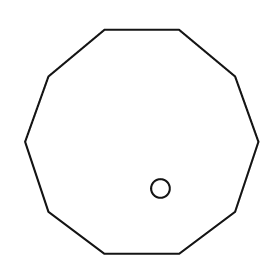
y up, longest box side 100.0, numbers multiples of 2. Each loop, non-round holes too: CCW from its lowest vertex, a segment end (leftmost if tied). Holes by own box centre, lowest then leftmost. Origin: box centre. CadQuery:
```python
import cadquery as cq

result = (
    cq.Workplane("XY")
    .moveTo(-16.0, -48.0)
    .lineTo(16.0, -48.0)
    .lineTo(40.0, -30.0)
    .lineTo(50.0, 0.0)
    .lineTo(40.0, 28.0)
    .lineTo(16.0, 48.0)
    .lineTo(-16.0, 48.0)
    .lineTo(-40.0, 28.0)
    .lineTo(-50.0, 0.0)
    .lineTo(-40.0, -30.0)
    .close()
    .moveTo(8.0, -20.0)
    .circle(4.0)
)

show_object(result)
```